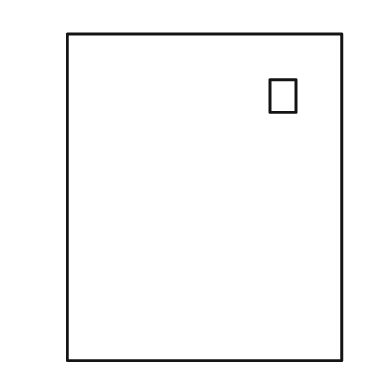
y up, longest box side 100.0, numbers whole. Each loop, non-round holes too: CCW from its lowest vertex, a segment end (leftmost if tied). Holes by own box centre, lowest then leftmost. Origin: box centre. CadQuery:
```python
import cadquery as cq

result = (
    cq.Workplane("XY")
    .moveTo(-42.0, -50.0)
    .lineTo(42.0, -50.0)
    .lineTo(42.0, 50.0)
    .lineTo(-42.0, 50.0)
    .close()
    .moveTo(20.0, 26.0)
    .lineTo(28.0, 26.0)
    .lineTo(28.0, 36.0)
    .lineTo(20.0, 36.0)
    .close()
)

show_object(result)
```